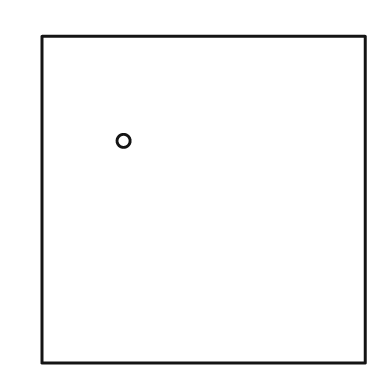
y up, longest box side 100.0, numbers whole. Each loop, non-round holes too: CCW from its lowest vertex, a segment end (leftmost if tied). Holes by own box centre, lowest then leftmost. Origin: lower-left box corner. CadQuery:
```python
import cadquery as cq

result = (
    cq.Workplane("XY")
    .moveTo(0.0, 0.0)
    .lineTo(99.0, 0.0)
    .lineTo(99.0, 100.0)
    .lineTo(0.0, 100.0)
    .close()
    .moveTo(25.0, 68.0)
    .circle(2.0)
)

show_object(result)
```